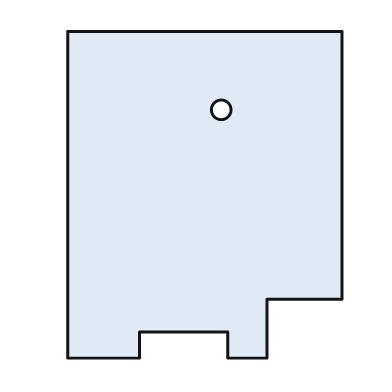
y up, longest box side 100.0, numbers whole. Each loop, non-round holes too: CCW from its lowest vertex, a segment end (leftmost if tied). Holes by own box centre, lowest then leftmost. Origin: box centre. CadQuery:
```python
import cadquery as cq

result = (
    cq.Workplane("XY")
    .moveTo(-42.0, -50.0)
    .lineTo(-20.0, -50.0)
    .lineTo(-20.0, -42.0)
    .lineTo(7.0, -42.0)
    .lineTo(7.0, -50.0)
    .lineTo(19.0, -50.0)
    .lineTo(19.0, -32.0)
    .lineTo(42.0, -32.0)
    .lineTo(42.0, 50.0)
    .lineTo(-42.0, 50.0)
    .close()
    .moveTo(5.0, 26.0)
    .circle(3.0)
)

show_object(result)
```